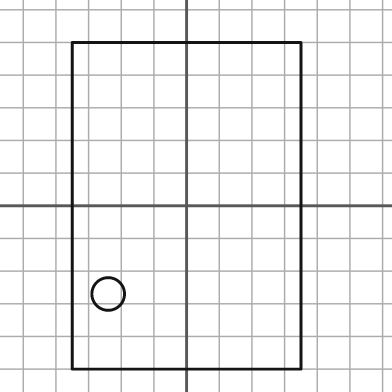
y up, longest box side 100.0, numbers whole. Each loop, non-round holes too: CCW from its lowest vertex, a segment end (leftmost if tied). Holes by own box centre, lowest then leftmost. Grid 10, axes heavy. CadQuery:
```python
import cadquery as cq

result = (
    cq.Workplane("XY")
    .moveTo(-35.0, -50.0)
    .lineTo(35.0, -50.0)
    .lineTo(35.0, 50.0)
    .lineTo(-35.0, 50.0)
    .close()
    .moveTo(-24.0, -27.0)
    .circle(5.0)
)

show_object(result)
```